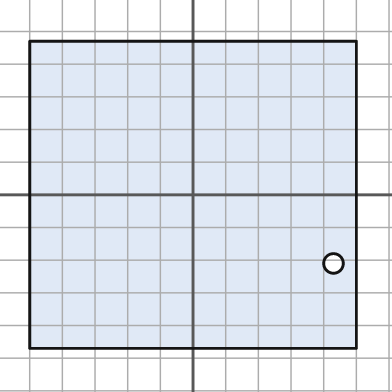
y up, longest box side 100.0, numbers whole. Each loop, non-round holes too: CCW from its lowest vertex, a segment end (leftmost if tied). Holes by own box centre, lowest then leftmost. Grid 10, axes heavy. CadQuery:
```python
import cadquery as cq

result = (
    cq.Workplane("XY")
    .moveTo(-50.0, -47.0)
    .lineTo(50.0, -47.0)
    .lineTo(50.0, 47.0)
    .lineTo(-50.0, 47.0)
    .close()
    .moveTo(43.0, -21.0)
    .circle(3.0)
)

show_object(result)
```